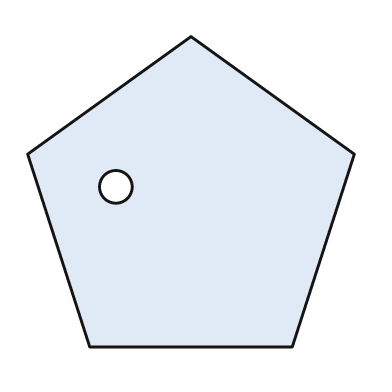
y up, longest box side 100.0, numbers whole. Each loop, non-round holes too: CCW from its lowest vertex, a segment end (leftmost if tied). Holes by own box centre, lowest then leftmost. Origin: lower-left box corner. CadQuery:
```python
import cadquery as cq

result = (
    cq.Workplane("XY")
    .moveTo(19.0, 0.0)
    .lineTo(81.0, 0.0)
    .lineTo(100.0, 59.0)
    .lineTo(50.0, 95.0)
    .lineTo(0.0, 59.0)
    .close()
    .moveTo(27.0, 49.0)
    .circle(5.0)
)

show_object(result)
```